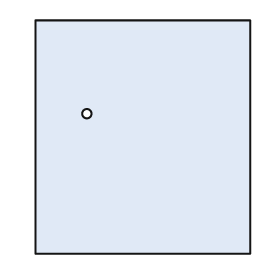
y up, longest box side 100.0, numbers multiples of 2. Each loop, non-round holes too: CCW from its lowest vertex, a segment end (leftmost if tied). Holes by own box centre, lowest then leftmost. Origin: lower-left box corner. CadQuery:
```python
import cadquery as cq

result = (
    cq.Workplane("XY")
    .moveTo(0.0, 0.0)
    .lineTo(92.0, 0.0)
    .lineTo(92.0, 100.0)
    .lineTo(0.0, 100.0)
    .close()
    .moveTo(22.0, 60.0)
    .circle(2.0)
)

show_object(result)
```